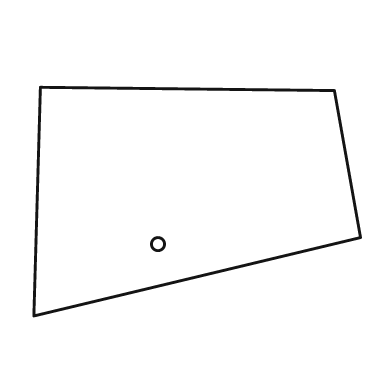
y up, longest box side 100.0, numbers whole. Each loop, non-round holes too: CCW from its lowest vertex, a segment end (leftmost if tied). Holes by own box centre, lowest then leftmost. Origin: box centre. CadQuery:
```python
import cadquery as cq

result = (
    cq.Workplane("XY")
    .moveTo(-50.0, -35.0)
    .lineTo(50.0, -11.0)
    .lineTo(42.0, 34.0)
    .lineTo(-48.0, 35.0)
    .close()
    .moveTo(-12.0, -13.0)
    .circle(2.0)
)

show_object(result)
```